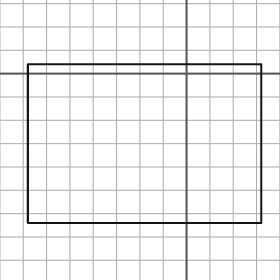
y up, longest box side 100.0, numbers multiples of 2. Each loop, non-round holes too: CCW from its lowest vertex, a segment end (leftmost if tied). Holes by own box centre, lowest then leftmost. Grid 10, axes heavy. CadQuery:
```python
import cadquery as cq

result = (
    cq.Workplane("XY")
    .moveTo(-68.0, -64.0)
    .lineTo(32.0, -64.0)
    .lineTo(32.0, 4.0)
    .lineTo(-68.0, 4.0)
    .close()
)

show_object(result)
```